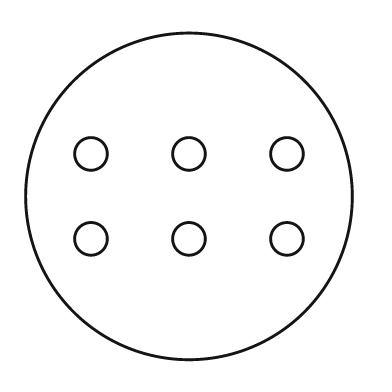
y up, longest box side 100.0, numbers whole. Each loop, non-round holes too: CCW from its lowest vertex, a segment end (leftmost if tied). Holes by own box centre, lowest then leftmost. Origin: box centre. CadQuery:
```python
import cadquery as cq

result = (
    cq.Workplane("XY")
    .moveTo(0.0, 0.0)
    .circle(50.0)
    .moveTo(-30.0, -13.0)
    .circle(5.0)
    .moveTo(0.0, -13.0)
    .circle(5.0)
    .moveTo(30.0, -13.0)
    .circle(5.0)
    .moveTo(-30.0, 13.0)
    .circle(5.0)
    .moveTo(0.0, 13.0)
    .circle(5.0)
    .moveTo(30.0, 13.0)
    .circle(5.0)
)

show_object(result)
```